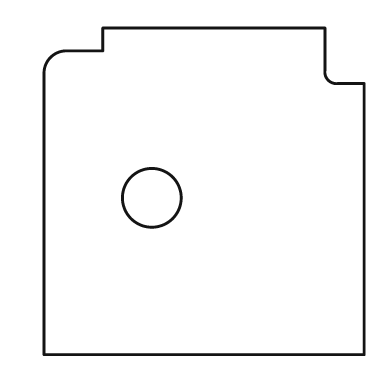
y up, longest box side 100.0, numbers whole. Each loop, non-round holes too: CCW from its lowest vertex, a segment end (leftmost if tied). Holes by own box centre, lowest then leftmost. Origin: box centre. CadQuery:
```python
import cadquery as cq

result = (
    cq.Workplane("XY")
    .moveTo(-49.0, -50.0)
    .lineTo(49.0, -50.0)
    .lineTo(49.0, 33.0)
    .lineTo(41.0, 33.0)
    .threePointArc((38.0, 34.0), (37.0, 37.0))
    .lineTo(37.0, 50.0)
    .lineTo(-31.0, 50.0)
    .lineTo(-31.0, 43.0)
    .lineTo(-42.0, 43.0)
    .threePointArc((-47.0, 41.0), (-49.0, 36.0))
    .close()
    .moveTo(-16.0, -2.0)
    .circle(9.0)
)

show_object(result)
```